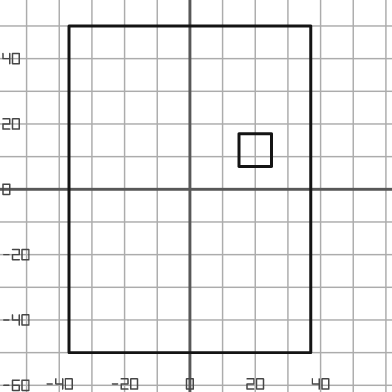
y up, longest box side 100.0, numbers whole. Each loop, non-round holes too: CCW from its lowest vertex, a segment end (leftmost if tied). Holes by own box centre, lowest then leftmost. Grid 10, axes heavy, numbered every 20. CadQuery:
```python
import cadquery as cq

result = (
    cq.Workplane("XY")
    .moveTo(-37.0, -50.0)
    .lineTo(37.0, -50.0)
    .lineTo(37.0, 50.0)
    .lineTo(-37.0, 50.0)
    .close()
    .moveTo(15.0, 7.0)
    .lineTo(25.0, 7.0)
    .lineTo(25.0, 17.0)
    .lineTo(15.0, 17.0)
    .close()
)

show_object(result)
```